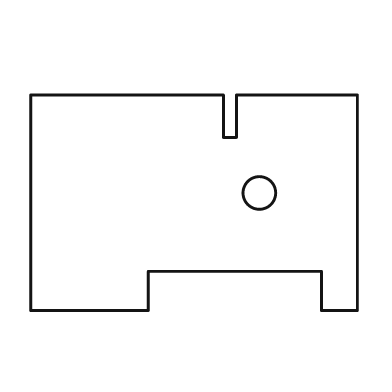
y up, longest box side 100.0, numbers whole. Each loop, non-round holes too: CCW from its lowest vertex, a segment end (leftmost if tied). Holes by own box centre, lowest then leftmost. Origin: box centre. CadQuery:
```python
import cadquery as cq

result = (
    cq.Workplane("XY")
    .moveTo(-50.0, -33.0)
    .lineTo(-14.0, -33.0)
    .lineTo(-14.0, -21.0)
    .lineTo(39.0, -21.0)
    .lineTo(39.0, -33.0)
    .lineTo(50.0, -33.0)
    .lineTo(50.0, 33.0)
    .lineTo(13.0, 33.0)
    .lineTo(13.0, 20.0)
    .lineTo(9.0, 20.0)
    .lineTo(9.0, 33.0)
    .lineTo(-50.0, 33.0)
    .close()
    .moveTo(20.0, 3.0)
    .circle(5.0)
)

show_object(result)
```